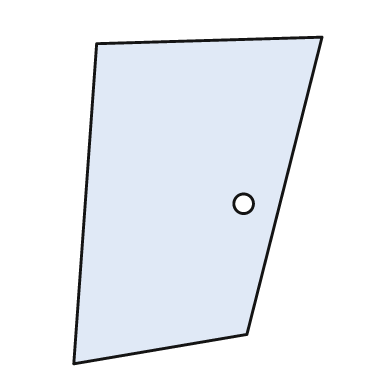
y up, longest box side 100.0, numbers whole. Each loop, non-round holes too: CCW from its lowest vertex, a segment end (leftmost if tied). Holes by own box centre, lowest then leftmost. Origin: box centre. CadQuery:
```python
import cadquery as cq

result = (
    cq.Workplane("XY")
    .moveTo(-38.0, -50.0)
    .lineTo(15.0, -41.0)
    .lineTo(38.0, 50.0)
    .lineTo(-31.0, 48.0)
    .close()
    .moveTo(14.0, -1.0)
    .circle(3.0)
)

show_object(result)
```